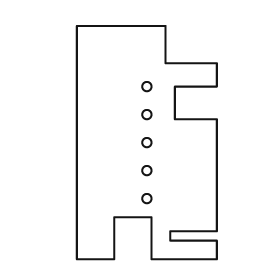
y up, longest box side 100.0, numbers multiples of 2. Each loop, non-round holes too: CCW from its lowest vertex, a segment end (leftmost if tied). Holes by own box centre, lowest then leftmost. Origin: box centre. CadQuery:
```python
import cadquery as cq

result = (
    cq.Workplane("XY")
    .moveTo(-30.0, -50.0)
    .lineTo(-14.0, -50.0)
    .lineTo(-14.0, -32.0)
    .lineTo(2.0, -32.0)
    .lineTo(2.0, -50.0)
    .lineTo(30.0, -50.0)
    .lineTo(30.0, -42.0)
    .lineTo(10.0, -42.0)
    .lineTo(10.0, -38.0)
    .lineTo(30.0, -38.0)
    .lineTo(30.0, 10.0)
    .lineTo(12.0, 10.0)
    .lineTo(12.0, 24.0)
    .lineTo(30.0, 24.0)
    .lineTo(30.0, 34.0)
    .lineTo(8.0, 34.0)
    .lineTo(8.0, 50.0)
    .lineTo(-30.0, 50.0)
    .close()
    .moveTo(0.0, -24.0)
    .circle(2.0)
    .moveTo(0.0, -12.0)
    .circle(2.0)
    .moveTo(0.0, 0.0)
    .circle(2.0)
    .moveTo(0.0, 12.0)
    .circle(2.0)
    .moveTo(0.0, 24.0)
    .circle(2.0)
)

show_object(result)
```